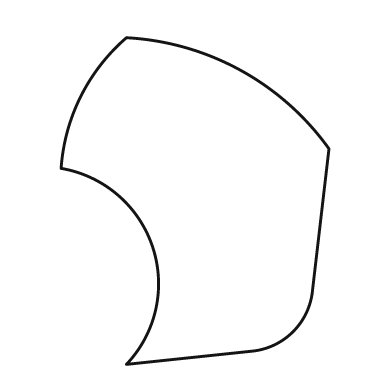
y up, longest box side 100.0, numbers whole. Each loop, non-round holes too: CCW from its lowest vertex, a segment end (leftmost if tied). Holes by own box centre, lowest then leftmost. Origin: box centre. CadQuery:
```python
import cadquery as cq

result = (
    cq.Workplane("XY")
    .moveTo(-21.0, -50.0)
    .lineTo(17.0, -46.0)
    .threePointArc((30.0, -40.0), (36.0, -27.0))
    .lineTo(41.0, 16.0)
    .threePointArc((14.0, 40.0), (-21.0, 50.0))
    .threePointArc((-35.0, 32.0), (-41.0, 10.0))
    .threePointArc((-13.0, -14.0), (-21.0, -50.0))
    .close()
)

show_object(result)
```